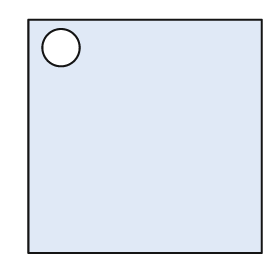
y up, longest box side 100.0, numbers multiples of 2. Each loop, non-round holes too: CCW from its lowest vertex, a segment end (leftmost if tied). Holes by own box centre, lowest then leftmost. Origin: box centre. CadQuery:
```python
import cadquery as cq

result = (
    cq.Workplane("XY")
    .moveTo(-50.0, -50.0)
    .lineTo(50.0, -50.0)
    .lineTo(50.0, 50.0)
    .lineTo(-50.0, 50.0)
    .close()
    .moveTo(-36.0, 38.0)
    .circle(8.0)
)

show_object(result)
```